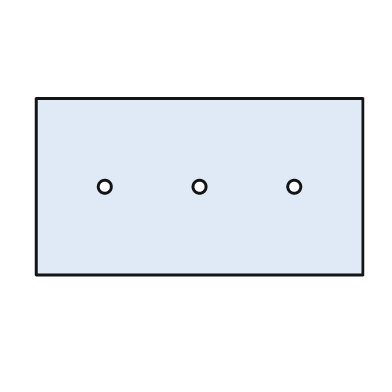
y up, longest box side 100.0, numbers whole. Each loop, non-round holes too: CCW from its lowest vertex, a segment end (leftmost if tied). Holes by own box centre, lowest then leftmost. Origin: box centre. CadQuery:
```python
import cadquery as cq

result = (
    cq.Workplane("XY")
    .moveTo(-50.0, -27.0)
    .lineTo(50.0, -27.0)
    .lineTo(50.0, 27.0)
    .lineTo(-50.0, 27.0)
    .close()
    .moveTo(-29.0, 0.0)
    .circle(2.0)
    .moveTo(0.0, 0.0)
    .circle(2.0)
    .moveTo(29.0, 0.0)
    .circle(2.0)
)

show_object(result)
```